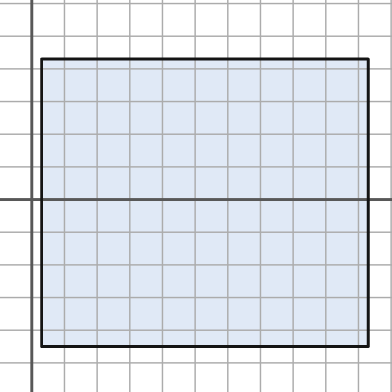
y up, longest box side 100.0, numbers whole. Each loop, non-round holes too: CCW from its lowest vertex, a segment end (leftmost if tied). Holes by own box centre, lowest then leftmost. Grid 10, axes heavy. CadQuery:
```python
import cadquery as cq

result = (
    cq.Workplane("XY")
    .moveTo(3.0, -45.0)
    .lineTo(103.0, -45.0)
    .lineTo(103.0, 43.0)
    .lineTo(3.0, 43.0)
    .close()
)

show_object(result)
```